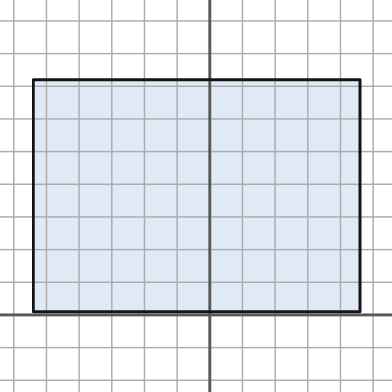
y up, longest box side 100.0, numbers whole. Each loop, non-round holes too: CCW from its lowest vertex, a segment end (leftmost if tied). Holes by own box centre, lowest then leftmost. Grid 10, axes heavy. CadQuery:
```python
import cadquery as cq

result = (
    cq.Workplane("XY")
    .moveTo(-54.0, 1.0)
    .lineTo(46.0, 1.0)
    .lineTo(46.0, 72.0)
    .lineTo(-54.0, 72.0)
    .close()
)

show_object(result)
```